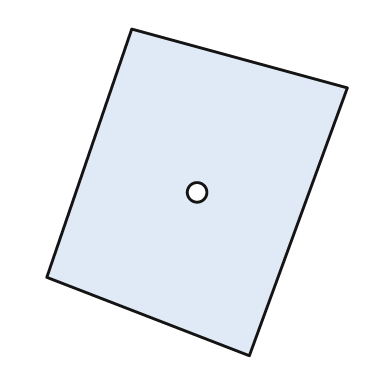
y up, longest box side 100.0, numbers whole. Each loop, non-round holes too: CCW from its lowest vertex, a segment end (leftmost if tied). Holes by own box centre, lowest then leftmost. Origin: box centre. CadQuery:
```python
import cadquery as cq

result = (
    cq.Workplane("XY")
    .moveTo(16.0, -50.0)
    .lineTo(46.0, 32.0)
    .lineTo(-20.0, 50.0)
    .lineTo(-46.0, -26.0)
    .close()
    .moveTo(0.0, 0.0)
    .circle(3.0)
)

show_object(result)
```